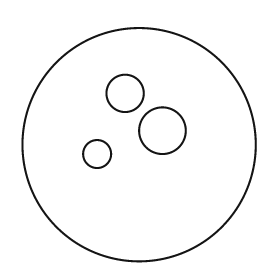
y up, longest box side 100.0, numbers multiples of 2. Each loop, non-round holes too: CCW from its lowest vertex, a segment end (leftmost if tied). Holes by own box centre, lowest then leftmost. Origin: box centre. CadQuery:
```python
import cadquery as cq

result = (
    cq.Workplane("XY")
    .moveTo(0.0, 0.0)
    .circle(50.0)
    .moveTo(-18.0, -4.0)
    .circle(6.0)
    .moveTo(10.0, 6.0)
    .circle(10.0)
    .moveTo(-6.0, 22.0)
    .circle(8.0)
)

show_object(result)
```